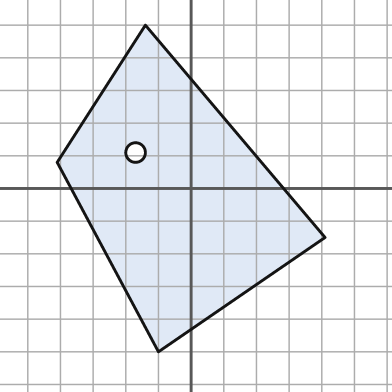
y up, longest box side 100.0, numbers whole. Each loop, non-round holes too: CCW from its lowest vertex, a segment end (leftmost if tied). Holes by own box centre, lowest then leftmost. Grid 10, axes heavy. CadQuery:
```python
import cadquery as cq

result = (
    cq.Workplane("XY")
    .moveTo(-10.0, -50.0)
    .lineTo(41.0, -15.0)
    .lineTo(-14.0, 50.0)
    .lineTo(-41.0, 8.0)
    .close()
    .moveTo(-17.0, 11.0)
    .circle(3.0)
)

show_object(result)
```